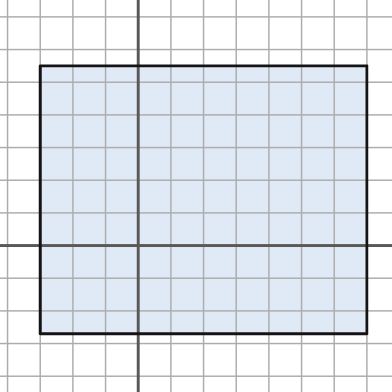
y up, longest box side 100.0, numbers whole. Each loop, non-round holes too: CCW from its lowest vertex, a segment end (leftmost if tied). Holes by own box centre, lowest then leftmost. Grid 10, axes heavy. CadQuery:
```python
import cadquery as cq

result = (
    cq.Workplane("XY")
    .moveTo(-30.0, -27.0)
    .lineTo(70.0, -27.0)
    .lineTo(70.0, 55.0)
    .lineTo(-30.0, 55.0)
    .close()
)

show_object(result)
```